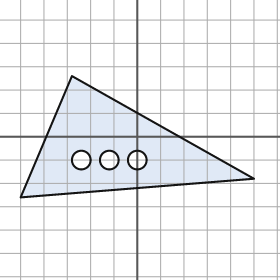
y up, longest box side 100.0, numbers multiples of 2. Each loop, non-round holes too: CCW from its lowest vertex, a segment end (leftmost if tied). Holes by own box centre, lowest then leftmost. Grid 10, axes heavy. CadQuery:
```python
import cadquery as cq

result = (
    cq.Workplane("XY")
    .moveTo(-50.0, -26.0)
    .lineTo(50.0, -18.0)
    .lineTo(-28.0, 26.0)
    .close()
    .moveTo(-24.0, -10.0)
    .circle(4.0)
    .moveTo(-12.0, -10.0)
    .circle(4.0)
    .moveTo(0.0, -10.0)
    .circle(4.0)
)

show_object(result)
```